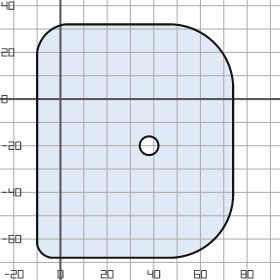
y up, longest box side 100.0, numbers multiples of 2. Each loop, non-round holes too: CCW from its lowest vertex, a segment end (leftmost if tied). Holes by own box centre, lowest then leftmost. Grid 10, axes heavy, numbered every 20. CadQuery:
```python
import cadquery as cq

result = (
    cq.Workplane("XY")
    .moveTo(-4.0, -68.0)
    .lineTo(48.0, -68.0)
    .threePointArc((66.0, -60.0), (74.0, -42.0))
    .lineTo(74.0, 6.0)
    .threePointArc((66.0, 24.0), (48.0, 32.0))
    .lineTo(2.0, 32.0)
    .threePointArc((-6.0, 28.0), (-10.0, 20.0))
    .lineTo(-10.0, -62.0)
    .threePointArc((-8.0, -66.0), (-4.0, -68.0))
    .close()
    .moveTo(38.0, -20.0)
    .circle(4.0)
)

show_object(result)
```